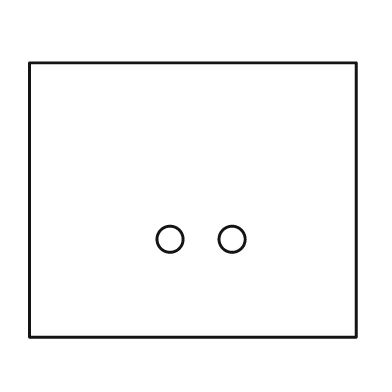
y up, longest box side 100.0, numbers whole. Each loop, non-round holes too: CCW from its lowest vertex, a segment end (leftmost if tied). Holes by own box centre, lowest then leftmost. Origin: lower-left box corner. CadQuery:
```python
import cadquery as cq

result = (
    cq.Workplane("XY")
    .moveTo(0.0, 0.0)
    .lineTo(100.0, 0.0)
    .lineTo(100.0, 84.0)
    .lineTo(0.0, 84.0)
    .close()
    .moveTo(43.0, 30.0)
    .circle(4.0)
    .moveTo(62.0, 30.0)
    .circle(4.0)
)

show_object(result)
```